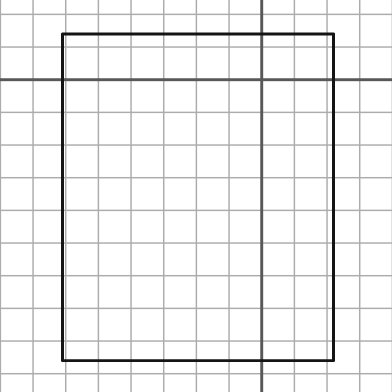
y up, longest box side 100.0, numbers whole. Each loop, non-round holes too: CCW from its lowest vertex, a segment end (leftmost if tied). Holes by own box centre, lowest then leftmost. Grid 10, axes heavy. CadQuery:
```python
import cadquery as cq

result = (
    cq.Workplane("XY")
    .moveTo(-61.0, -86.0)
    .lineTo(22.0, -86.0)
    .lineTo(22.0, 14.0)
    .lineTo(-61.0, 14.0)
    .close()
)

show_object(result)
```